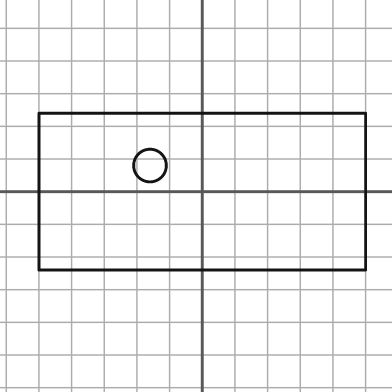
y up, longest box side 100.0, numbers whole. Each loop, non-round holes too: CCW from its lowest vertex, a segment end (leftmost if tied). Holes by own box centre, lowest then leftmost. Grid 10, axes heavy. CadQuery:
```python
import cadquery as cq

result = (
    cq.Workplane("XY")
    .moveTo(-50.0, -24.0)
    .lineTo(50.0, -24.0)
    .lineTo(50.0, 24.0)
    .lineTo(-50.0, 24.0)
    .close()
    .moveTo(-16.0, 8.0)
    .circle(5.0)
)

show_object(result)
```